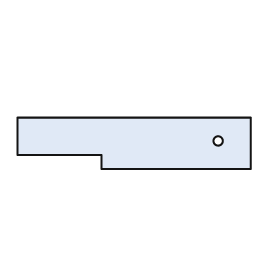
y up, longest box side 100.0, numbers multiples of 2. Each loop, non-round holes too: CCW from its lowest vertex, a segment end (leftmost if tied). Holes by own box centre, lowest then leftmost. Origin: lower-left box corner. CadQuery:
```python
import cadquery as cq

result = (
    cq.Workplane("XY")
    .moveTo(36.0, 0.0)
    .lineTo(100.0, 0.0)
    .lineTo(100.0, 22.0)
    .lineTo(0.0, 22.0)
    .lineTo(0.0, 6.0)
    .lineTo(36.0, 6.0)
    .close()
    .moveTo(86.0, 12.0)
    .circle(2.0)
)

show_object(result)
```